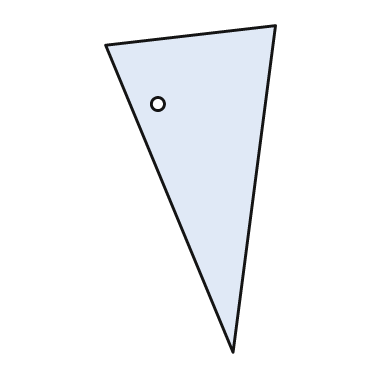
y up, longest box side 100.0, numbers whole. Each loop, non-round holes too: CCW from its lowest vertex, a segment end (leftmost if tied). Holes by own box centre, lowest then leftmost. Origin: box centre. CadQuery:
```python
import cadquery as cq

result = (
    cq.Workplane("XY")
    .moveTo(13.0, -50.0)
    .lineTo(26.0, 50.0)
    .lineTo(-26.0, 44.0)
    .close()
    .moveTo(-10.0, 26.0)
    .circle(2.0)
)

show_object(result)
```